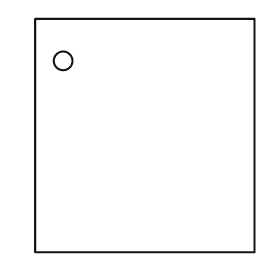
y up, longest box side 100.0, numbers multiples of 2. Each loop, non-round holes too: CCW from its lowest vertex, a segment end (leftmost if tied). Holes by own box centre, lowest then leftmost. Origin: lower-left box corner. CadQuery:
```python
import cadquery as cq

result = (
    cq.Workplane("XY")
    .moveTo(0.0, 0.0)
    .lineTo(94.0, 0.0)
    .lineTo(94.0, 100.0)
    .lineTo(0.0, 100.0)
    .close()
    .moveTo(12.0, 82.0)
    .circle(4.0)
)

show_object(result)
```